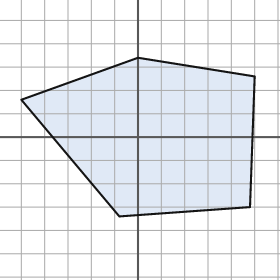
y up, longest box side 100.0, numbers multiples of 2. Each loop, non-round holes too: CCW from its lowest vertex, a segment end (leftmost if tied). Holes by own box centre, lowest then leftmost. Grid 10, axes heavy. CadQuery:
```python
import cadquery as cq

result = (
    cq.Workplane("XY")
    .moveTo(-8.0, -34.0)
    .lineTo(48.0, -30.0)
    .lineTo(50.0, 26.0)
    .lineTo(0.0, 34.0)
    .lineTo(-50.0, 16.0)
    .close()
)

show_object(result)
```